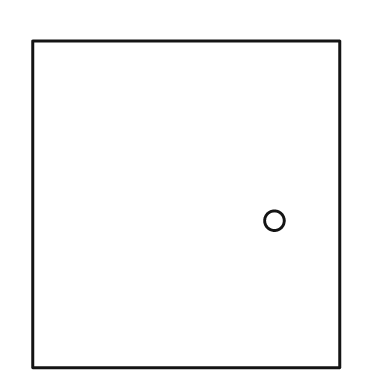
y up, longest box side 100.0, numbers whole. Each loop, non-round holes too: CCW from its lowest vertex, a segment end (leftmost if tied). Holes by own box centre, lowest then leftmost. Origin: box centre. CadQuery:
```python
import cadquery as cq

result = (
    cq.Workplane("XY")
    .moveTo(-47.0, -50.0)
    .lineTo(47.0, -50.0)
    .lineTo(47.0, 50.0)
    .lineTo(-47.0, 50.0)
    .close()
    .moveTo(27.0, -5.0)
    .circle(3.0)
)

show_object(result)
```